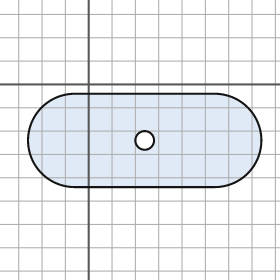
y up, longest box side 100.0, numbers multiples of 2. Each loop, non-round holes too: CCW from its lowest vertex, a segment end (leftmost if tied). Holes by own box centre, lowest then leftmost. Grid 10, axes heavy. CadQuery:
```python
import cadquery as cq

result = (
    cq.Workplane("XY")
    .moveTo(-6.0, -44.0)
    .lineTo(54.0, -44.0)
    .threePointArc((74.0, -24.0), (54.0, -4.0))
    .lineTo(-6.0, -4.0)
    .threePointArc((-26.0, -24.0), (-6.0, -44.0))
    .close()
    .moveTo(24.0, -24.0)
    .circle(4.0)
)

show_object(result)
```